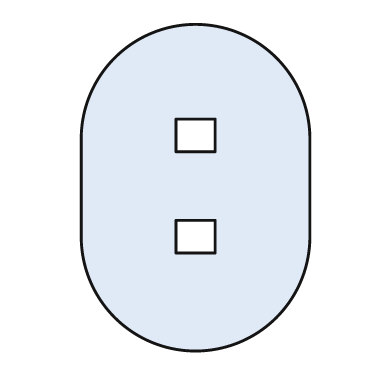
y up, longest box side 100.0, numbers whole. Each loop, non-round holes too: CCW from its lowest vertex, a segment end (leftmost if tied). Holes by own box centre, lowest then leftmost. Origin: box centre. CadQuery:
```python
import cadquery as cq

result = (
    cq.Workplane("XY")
    .moveTo(-35.0, -15.0)
    .threePointArc((0.0, -50.0), (35.0, -15.0))
    .lineTo(35.0, 15.0)
    .threePointArc((0.0, 50.0), (-35.0, 15.0))
    .close()
    .moveTo(-6.0, -20.0)
    .lineTo(6.0, -20.0)
    .lineTo(6.0, -10.0)
    .lineTo(-6.0, -10.0)
    .close()
    .moveTo(-6.0, 11.0)
    .lineTo(6.0, 11.0)
    .lineTo(6.0, 21.0)
    .lineTo(-6.0, 21.0)
    .close()
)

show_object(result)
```